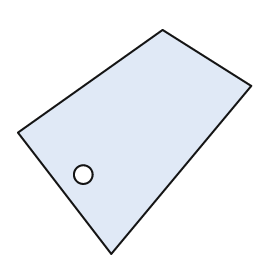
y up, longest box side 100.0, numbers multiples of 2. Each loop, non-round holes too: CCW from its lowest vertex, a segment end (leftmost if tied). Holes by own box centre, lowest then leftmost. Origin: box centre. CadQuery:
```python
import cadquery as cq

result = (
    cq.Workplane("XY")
    .moveTo(-10.0, -48.0)
    .lineTo(50.0, 24.0)
    .lineTo(12.0, 48.0)
    .lineTo(-50.0, 4.0)
    .close()
    .moveTo(-22.0, -14.0)
    .circle(4.0)
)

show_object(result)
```